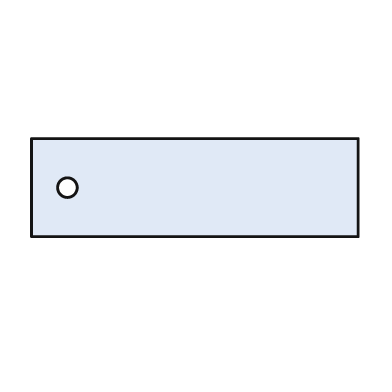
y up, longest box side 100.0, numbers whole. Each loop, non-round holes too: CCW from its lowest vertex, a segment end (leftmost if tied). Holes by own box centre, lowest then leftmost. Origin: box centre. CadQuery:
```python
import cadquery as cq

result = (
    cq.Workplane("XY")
    .moveTo(-50.0, -15.0)
    .lineTo(50.0, -15.0)
    .lineTo(50.0, 15.0)
    .lineTo(-50.0, 15.0)
    .close()
    .moveTo(-39.0, 0.0)
    .circle(3.0)
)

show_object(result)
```